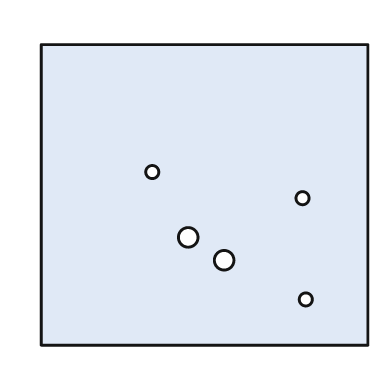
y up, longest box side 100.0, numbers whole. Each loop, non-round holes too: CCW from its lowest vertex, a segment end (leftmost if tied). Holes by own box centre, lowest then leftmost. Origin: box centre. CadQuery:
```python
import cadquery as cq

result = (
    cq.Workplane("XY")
    .moveTo(-50.0, -46.0)
    .lineTo(50.0, -46.0)
    .lineTo(50.0, 46.0)
    .lineTo(-50.0, 46.0)
    .close()
    .moveTo(31.0, -32.0)
    .circle(2.0)
    .moveTo(6.0, -20.0)
    .circle(3.0)
    .moveTo(-5.0, -13.0)
    .circle(3.0)
    .moveTo(30.0, -1.0)
    .circle(2.0)
    .moveTo(-16.0, 7.0)
    .circle(2.0)
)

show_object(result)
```